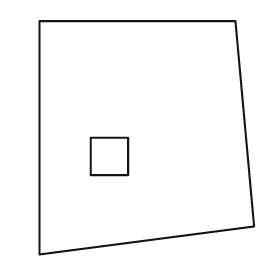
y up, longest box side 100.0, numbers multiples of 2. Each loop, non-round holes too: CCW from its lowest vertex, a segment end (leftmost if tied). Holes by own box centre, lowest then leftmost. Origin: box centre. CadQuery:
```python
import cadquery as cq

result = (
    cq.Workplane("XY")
    .moveTo(-46.0, -50.0)
    .lineTo(46.0, -38.0)
    .lineTo(38.0, 50.0)
    .lineTo(-46.0, 50.0)
    .close()
    .moveTo(-24.0, -16.0)
    .lineTo(-8.0, -16.0)
    .lineTo(-8.0, 0.0)
    .lineTo(-24.0, 0.0)
    .close()
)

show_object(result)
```